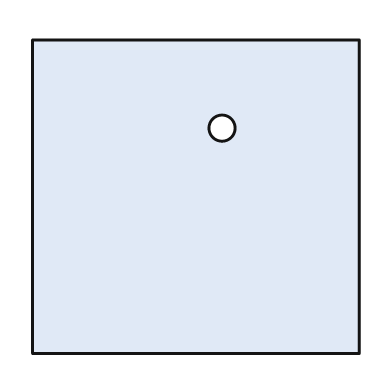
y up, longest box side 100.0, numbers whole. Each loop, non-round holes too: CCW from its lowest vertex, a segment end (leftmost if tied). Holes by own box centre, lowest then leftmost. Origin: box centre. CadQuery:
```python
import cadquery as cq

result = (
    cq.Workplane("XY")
    .moveTo(-50.0, -48.0)
    .lineTo(50.0, -48.0)
    .lineTo(50.0, 48.0)
    .lineTo(-50.0, 48.0)
    .close()
    .moveTo(8.0, 21.0)
    .circle(4.0)
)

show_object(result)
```